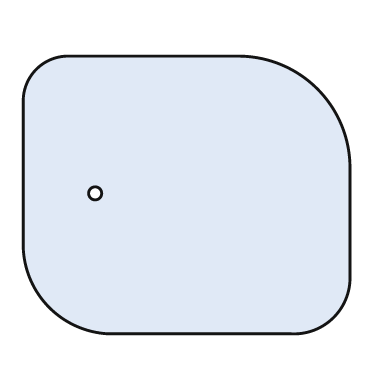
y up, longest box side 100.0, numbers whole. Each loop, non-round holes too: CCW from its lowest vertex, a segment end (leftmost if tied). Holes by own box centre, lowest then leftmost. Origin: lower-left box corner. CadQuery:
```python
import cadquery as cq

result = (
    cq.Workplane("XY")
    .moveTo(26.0, 0.0)
    .lineTo(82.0, 0.0)
    .threePointArc((95.0, 5.0), (100.0, 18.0))
    .lineTo(100.0, 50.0)
    .threePointArc((90.0, 75.0), (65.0, 85.0))
    .lineTo(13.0, 85.0)
    .threePointArc((4.0, 81.0), (0.0, 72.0))
    .lineTo(0.0, 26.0)
    .threePointArc((8.0, 8.0), (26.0, 0.0))
    .close()
    .moveTo(22.0, 43.0)
    .circle(2.0)
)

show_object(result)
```